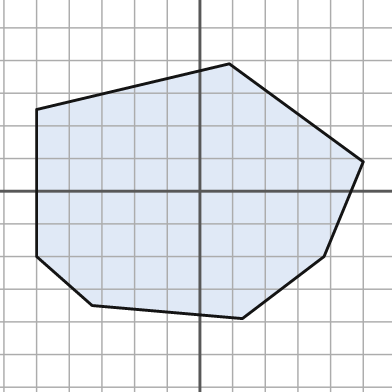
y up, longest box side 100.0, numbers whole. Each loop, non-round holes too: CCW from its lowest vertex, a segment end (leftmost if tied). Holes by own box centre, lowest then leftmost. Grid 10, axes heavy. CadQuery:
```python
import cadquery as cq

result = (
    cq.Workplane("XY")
    .moveTo(13.0, -39.0)
    .lineTo(38.0, -20.0)
    .lineTo(50.0, 9.0)
    .lineTo(9.0, 39.0)
    .lineTo(-50.0, 25.0)
    .lineTo(-50.0, -20.0)
    .lineTo(-33.0, -35.0)
    .close()
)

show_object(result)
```